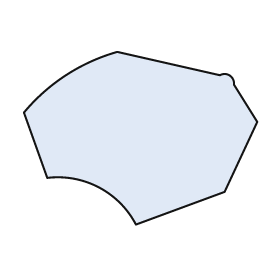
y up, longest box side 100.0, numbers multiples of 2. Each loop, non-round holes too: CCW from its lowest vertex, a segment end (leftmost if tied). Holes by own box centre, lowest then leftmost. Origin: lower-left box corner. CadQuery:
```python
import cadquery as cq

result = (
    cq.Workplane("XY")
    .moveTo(48.0, 0.0)
    .lineTo(86.0, 14.0)
    .lineTo(100.0, 44.0)
    .lineTo(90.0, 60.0)
    .threePointArc((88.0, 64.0), (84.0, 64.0))
    .lineTo(40.0, 74.0)
    .threePointArc((18.0, 64.0), (0.0, 48.0))
    .lineTo(10.0, 20.0)
    .threePointArc((32.0, 16.0), (48.0, 0.0))
    .close()
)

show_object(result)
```